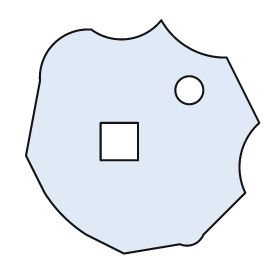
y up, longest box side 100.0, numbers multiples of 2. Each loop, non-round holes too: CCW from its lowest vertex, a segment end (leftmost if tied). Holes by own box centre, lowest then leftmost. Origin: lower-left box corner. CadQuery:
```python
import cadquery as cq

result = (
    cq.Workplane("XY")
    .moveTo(42.0, 0.0)
    .lineTo(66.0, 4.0)
    .threePointArc((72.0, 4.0), (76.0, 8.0))
    .lineTo(94.0, 26.0)
    .threePointArc((92.0, 42.0), (100.0, 56.0))
    .lineTo(86.0, 84.0)
    .threePointArc((70.0, 88.0), (58.0, 100.0))
    .threePointArc((44.0, 92.0), (28.0, 96.0))
    .threePointArc((12.0, 90.0), (6.0, 74.0))
    .lineTo(0.0, 42.0)
    .lineTo(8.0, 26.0)
    .threePointArc((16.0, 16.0), (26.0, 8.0))
    .close()
    .moveTo(32.0, 40.0)
    .lineTo(48.0, 40.0)
    .lineTo(48.0, 56.0)
    .lineTo(32.0, 56.0)
    .close()
    .moveTo(70.0, 70.0)
    .circle(6.0)
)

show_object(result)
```